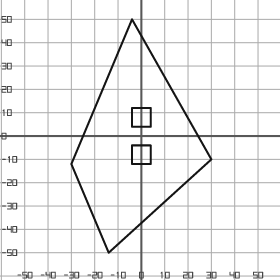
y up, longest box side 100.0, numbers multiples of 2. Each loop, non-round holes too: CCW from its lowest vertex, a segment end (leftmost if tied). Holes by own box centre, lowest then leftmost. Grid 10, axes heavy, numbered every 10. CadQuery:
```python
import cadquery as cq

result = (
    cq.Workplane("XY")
    .moveTo(-14.0, -50.0)
    .lineTo(30.0, -10.0)
    .lineTo(-4.0, 50.0)
    .lineTo(-30.0, -12.0)
    .close()
    .moveTo(-4.0, -12.0)
    .lineTo(4.0, -12.0)
    .lineTo(4.0, -4.0)
    .lineTo(-4.0, -4.0)
    .close()
    .moveTo(-4.0, 4.0)
    .lineTo(4.0, 4.0)
    .lineTo(4.0, 12.0)
    .lineTo(-4.0, 12.0)
    .close()
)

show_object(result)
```